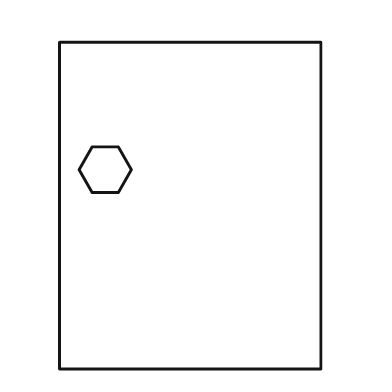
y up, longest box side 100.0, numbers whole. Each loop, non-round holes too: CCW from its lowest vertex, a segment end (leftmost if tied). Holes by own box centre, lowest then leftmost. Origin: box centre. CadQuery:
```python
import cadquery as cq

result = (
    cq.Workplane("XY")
    .moveTo(-40.0, -50.0)
    .lineTo(40.0, -50.0)
    .lineTo(40.0, 50.0)
    .lineTo(-40.0, 50.0)
    .close()
    .moveTo(-30.0, 4.0)
    .lineTo(-22.0, 4.0)
    .lineTo(-18.0, 11.0)
    .lineTo(-22.0, 18.0)
    .lineTo(-30.0, 18.0)
    .lineTo(-34.0, 11.0)
    .close()
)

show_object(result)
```